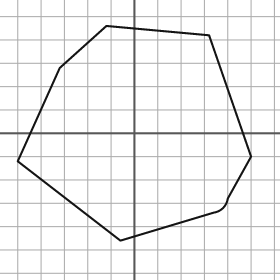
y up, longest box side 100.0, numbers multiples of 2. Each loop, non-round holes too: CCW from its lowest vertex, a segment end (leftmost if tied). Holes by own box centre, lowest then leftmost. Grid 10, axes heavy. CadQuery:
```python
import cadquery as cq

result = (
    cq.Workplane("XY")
    .moveTo(-6.0, -46.0)
    .lineTo(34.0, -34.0)
    .threePointArc((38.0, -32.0), (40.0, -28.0))
    .lineTo(50.0, -10.0)
    .lineTo(32.0, 42.0)
    .lineTo(-12.0, 46.0)
    .lineTo(-32.0, 28.0)
    .lineTo(-50.0, -12.0)
    .close()
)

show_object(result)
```